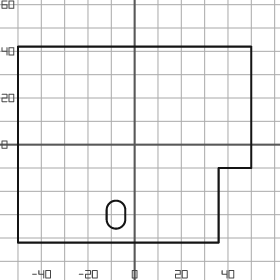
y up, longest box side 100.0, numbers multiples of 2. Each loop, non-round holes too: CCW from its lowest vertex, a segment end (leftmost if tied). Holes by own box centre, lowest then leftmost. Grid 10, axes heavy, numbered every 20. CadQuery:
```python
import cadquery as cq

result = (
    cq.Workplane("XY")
    .moveTo(-50.0, -42.0)
    .lineTo(36.0, -42.0)
    .lineTo(36.0, -10.0)
    .lineTo(50.0, -10.0)
    .lineTo(50.0, 42.0)
    .lineTo(-50.0, 42.0)
    .close()
    .moveTo(-12.0, -32.0)
    .threePointArc((-8.0, -36.0), (-4.0, -32.0))
    .lineTo(-4.0, -28.0)
    .threePointArc((-8.0, -24.0), (-12.0, -28.0))
    .close()
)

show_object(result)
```